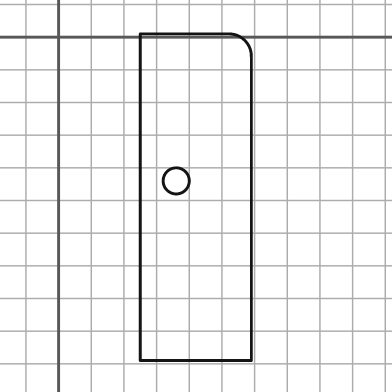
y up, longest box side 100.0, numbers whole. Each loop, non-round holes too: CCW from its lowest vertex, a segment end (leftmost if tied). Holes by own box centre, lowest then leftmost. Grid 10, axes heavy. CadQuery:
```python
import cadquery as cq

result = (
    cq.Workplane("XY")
    .moveTo(25.0, -99.0)
    .lineTo(59.0, -99.0)
    .lineTo(59.0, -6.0)
    .threePointArc((57.0, -1.0), (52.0, 1.0))
    .lineTo(25.0, 1.0)
    .close()
    .moveTo(36.0, -44.0)
    .circle(4.0)
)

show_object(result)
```